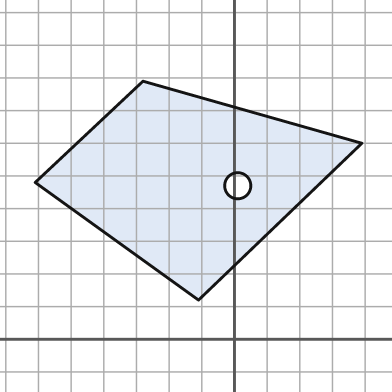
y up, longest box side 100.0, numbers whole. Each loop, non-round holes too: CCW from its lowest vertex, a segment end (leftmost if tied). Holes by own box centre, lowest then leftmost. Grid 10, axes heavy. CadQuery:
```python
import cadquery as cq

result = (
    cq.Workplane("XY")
    .moveTo(-11.0, 12.0)
    .lineTo(39.0, 60.0)
    .lineTo(-28.0, 79.0)
    .lineTo(-61.0, 48.0)
    .close()
    .moveTo(1.0, 47.0)
    .circle(4.0)
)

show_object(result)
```